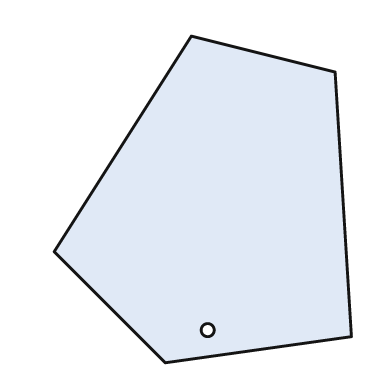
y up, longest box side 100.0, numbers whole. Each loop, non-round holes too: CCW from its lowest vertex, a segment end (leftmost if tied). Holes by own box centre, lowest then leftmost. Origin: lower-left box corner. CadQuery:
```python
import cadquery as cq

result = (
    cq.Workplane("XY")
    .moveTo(34.0, 0.0)
    .lineTo(91.0, 8.0)
    .lineTo(86.0, 89.0)
    .lineTo(42.0, 100.0)
    .lineTo(0.0, 34.0)
    .close()
    .moveTo(47.0, 10.0)
    .circle(2.0)
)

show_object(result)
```